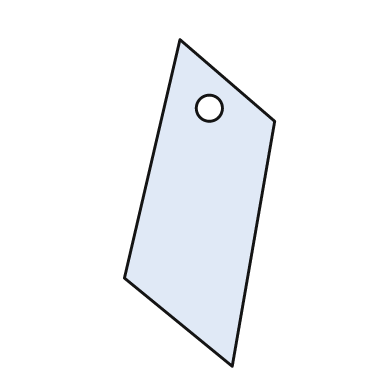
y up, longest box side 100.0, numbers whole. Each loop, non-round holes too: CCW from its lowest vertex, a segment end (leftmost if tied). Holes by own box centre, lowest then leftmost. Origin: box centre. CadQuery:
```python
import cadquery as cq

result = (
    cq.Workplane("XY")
    .moveTo(10.0, -50.0)
    .lineTo(23.0, 25.0)
    .lineTo(-6.0, 50.0)
    .lineTo(-23.0, -23.0)
    .close()
    .moveTo(3.0, 29.0)
    .circle(4.0)
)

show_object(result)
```